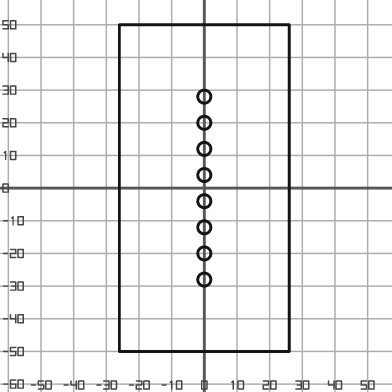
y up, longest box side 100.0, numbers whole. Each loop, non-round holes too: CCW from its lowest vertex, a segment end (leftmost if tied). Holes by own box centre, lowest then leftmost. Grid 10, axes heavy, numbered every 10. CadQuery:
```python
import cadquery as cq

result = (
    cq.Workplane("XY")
    .moveTo(-26.0, -50.0)
    .lineTo(26.0, -50.0)
    .lineTo(26.0, 50.0)
    .lineTo(-26.0, 50.0)
    .close()
    .moveTo(0.0, -28.0)
    .circle(2.0)
    .moveTo(0.0, -20.0)
    .circle(2.0)
    .moveTo(0.0, -12.0)
    .circle(2.0)
    .moveTo(0.0, -4.0)
    .circle(2.0)
    .moveTo(0.0, 4.0)
    .circle(2.0)
    .moveTo(0.0, 12.0)
    .circle(2.0)
    .moveTo(0.0, 20.0)
    .circle(2.0)
    .moveTo(0.0, 28.0)
    .circle(2.0)
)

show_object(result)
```